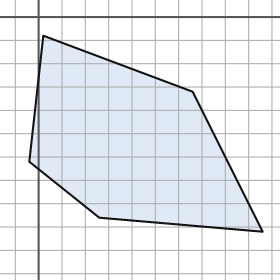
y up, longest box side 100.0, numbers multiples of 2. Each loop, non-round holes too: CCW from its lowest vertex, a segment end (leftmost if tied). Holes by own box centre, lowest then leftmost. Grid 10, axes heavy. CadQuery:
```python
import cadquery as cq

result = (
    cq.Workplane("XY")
    .moveTo(96.0, -92.0)
    .lineTo(66.0, -32.0)
    .lineTo(2.0, -8.0)
    .lineTo(-4.0, -62.0)
    .lineTo(26.0, -86.0)
    .close()
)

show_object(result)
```